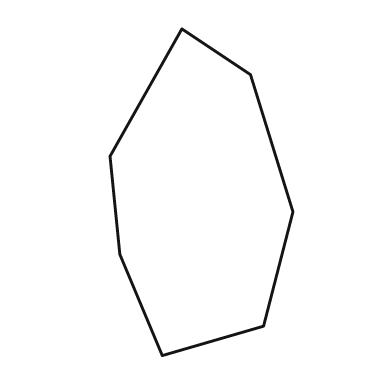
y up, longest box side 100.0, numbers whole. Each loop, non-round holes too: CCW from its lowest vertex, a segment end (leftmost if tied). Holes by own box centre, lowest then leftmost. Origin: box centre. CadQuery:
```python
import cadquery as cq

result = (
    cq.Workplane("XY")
    .moveTo(-12.0, -50.0)
    .lineTo(19.0, -41.0)
    .lineTo(28.0, -6.0)
    .lineTo(15.0, 36.0)
    .lineTo(-6.0, 50.0)
    .lineTo(-28.0, 11.0)
    .lineTo(-25.0, -19.0)
    .close()
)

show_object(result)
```